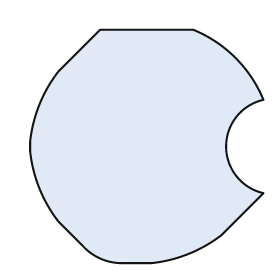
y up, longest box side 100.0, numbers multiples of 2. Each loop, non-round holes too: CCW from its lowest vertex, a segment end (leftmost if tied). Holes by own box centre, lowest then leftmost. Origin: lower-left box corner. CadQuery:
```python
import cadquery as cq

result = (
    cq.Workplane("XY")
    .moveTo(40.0, 0.0)
    .lineTo(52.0, 0.0)
    .threePointArc((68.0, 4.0), (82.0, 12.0))
    .lineTo(100.0, 30.0)
    .threePointArc((84.0, 50.0), (100.0, 70.0))
    .threePointArc((88.0, 88.0), (70.0, 100.0))
    .lineTo(30.0, 100.0)
    .lineTo(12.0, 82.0)
    .threePointArc((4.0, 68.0), (0.0, 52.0))
    .lineTo(0.0, 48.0)
    .threePointArc((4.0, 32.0), (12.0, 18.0))
    .lineTo(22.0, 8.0)
    .threePointArc((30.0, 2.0), (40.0, 0.0))
    .close()
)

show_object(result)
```